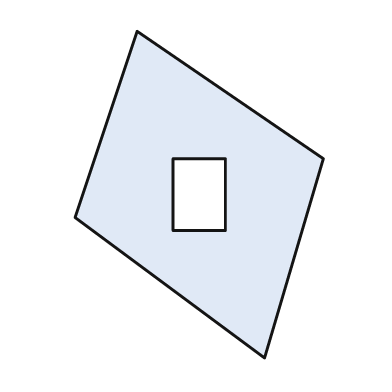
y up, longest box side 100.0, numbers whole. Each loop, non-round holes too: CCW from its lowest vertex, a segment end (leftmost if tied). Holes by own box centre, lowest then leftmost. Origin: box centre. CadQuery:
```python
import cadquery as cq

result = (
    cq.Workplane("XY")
    .moveTo(20.0, -50.0)
    .lineTo(38.0, 11.0)
    .lineTo(-19.0, 50.0)
    .lineTo(-38.0, -7.0)
    .close()
    .moveTo(-8.0, -11.0)
    .lineTo(8.0, -11.0)
    .lineTo(8.0, 11.0)
    .lineTo(-8.0, 11.0)
    .close()
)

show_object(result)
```